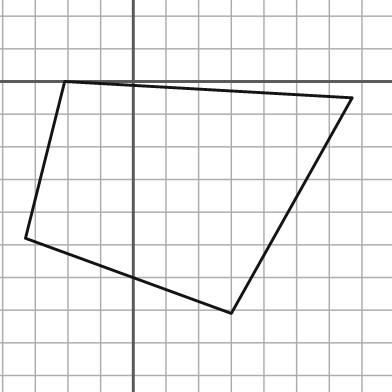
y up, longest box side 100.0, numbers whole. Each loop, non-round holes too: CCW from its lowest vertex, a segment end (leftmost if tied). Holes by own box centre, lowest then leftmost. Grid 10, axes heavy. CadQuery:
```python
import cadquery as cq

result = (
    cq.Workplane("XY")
    .moveTo(30.0, -71.0)
    .lineTo(67.0, -5.0)
    .lineTo(-21.0, 0.0)
    .lineTo(-33.0, -48.0)
    .close()
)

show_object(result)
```